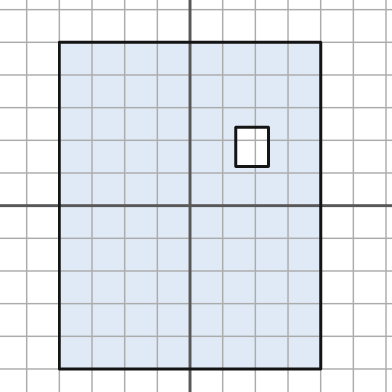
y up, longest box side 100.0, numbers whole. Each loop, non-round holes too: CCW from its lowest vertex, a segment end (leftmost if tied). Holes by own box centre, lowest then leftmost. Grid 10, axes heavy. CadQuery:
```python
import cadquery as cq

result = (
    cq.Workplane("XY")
    .moveTo(-40.0, -50.0)
    .lineTo(40.0, -50.0)
    .lineTo(40.0, 50.0)
    .lineTo(-40.0, 50.0)
    .close()
    .moveTo(14.0, 12.0)
    .lineTo(24.0, 12.0)
    .lineTo(24.0, 24.0)
    .lineTo(14.0, 24.0)
    .close()
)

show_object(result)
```